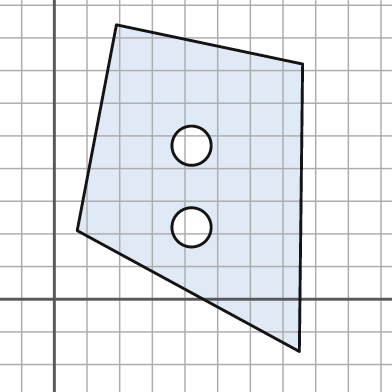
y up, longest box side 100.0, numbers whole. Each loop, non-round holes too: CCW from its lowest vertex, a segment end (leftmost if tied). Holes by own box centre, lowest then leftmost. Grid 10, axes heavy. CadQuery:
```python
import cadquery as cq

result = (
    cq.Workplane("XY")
    .moveTo(75.0, -16.0)
    .lineTo(76.0, 72.0)
    .lineTo(19.0, 84.0)
    .lineTo(7.0, 21.0)
    .close()
    .moveTo(42.0, 22.0)
    .circle(6.0)
    .moveTo(42.0, 47.0)
    .circle(6.0)
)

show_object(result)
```